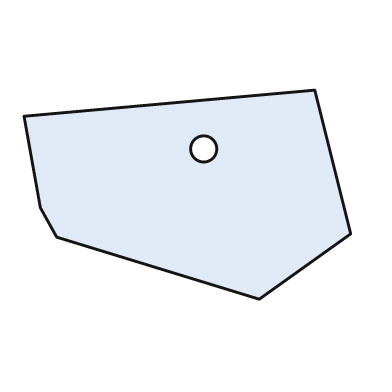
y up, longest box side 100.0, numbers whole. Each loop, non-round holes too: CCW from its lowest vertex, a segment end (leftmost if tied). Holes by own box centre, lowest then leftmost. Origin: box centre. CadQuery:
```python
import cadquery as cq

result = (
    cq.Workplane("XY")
    .moveTo(22.0, -32.0)
    .lineTo(50.0, -12.0)
    .lineTo(39.0, 32.0)
    .lineTo(-50.0, 24.0)
    .lineTo(-45.0, -4.0)
    .lineTo(-40.0, -13.0)
    .close()
    .moveTo(5.0, 14.0)
    .circle(4.0)
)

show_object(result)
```